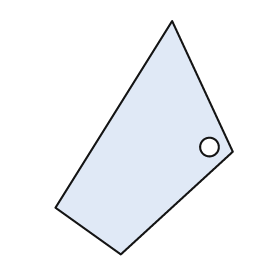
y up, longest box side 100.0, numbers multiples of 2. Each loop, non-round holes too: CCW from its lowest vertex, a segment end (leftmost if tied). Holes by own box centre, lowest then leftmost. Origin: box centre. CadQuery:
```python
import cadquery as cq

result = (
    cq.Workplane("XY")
    .moveTo(-10.0, -50.0)
    .lineTo(38.0, -6.0)
    .lineTo(12.0, 50.0)
    .lineTo(-38.0, -30.0)
    .close()
    .moveTo(28.0, -4.0)
    .circle(4.0)
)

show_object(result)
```